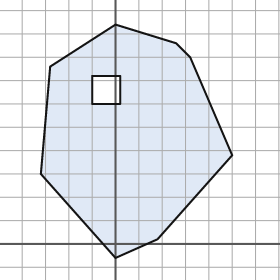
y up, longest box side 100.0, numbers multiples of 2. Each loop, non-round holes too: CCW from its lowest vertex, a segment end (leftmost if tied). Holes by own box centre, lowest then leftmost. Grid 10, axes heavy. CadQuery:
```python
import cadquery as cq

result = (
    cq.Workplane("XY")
    .moveTo(0.0, -6.0)
    .lineTo(18.0, 2.0)
    .lineTo(50.0, 38.0)
    .lineTo(32.0, 80.0)
    .lineTo(26.0, 86.0)
    .lineTo(0.0, 94.0)
    .lineTo(-28.0, 76.0)
    .lineTo(-32.0, 30.0)
    .close()
    .moveTo(-10.0, 60.0)
    .lineTo(2.0, 60.0)
    .lineTo(2.0, 72.0)
    .lineTo(-10.0, 72.0)
    .close()
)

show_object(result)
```